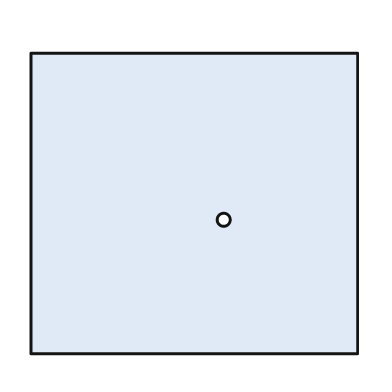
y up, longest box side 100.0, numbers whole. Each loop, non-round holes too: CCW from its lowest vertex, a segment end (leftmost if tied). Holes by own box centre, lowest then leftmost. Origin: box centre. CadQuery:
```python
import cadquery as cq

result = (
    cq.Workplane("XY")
    .moveTo(-50.0, -46.0)
    .lineTo(50.0, -46.0)
    .lineTo(50.0, 46.0)
    .lineTo(-50.0, 46.0)
    .close()
    .moveTo(9.0, -5.0)
    .circle(2.0)
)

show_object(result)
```